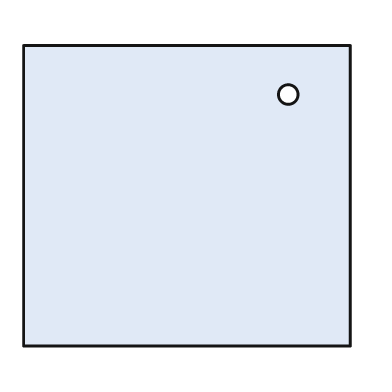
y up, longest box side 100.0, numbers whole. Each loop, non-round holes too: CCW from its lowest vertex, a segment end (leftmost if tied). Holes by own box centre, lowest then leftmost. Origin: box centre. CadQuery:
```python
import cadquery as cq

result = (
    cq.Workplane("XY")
    .moveTo(-50.0, -46.0)
    .lineTo(50.0, -46.0)
    .lineTo(50.0, 46.0)
    .lineTo(-50.0, 46.0)
    .close()
    .moveTo(31.0, 31.0)
    .circle(3.0)
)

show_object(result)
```